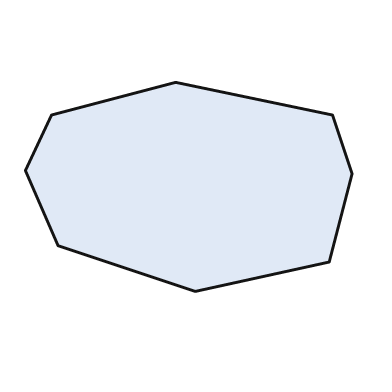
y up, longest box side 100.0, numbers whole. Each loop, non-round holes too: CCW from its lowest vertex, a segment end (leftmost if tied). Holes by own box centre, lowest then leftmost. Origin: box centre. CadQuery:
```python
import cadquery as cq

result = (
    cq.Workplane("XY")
    .moveTo(2.0, -32.0)
    .lineTo(43.0, -23.0)
    .lineTo(50.0, 4.0)
    .lineTo(44.0, 22.0)
    .lineTo(-4.0, 32.0)
    .lineTo(-42.0, 22.0)
    .lineTo(-50.0, 5.0)
    .lineTo(-40.0, -18.0)
    .close()
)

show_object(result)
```